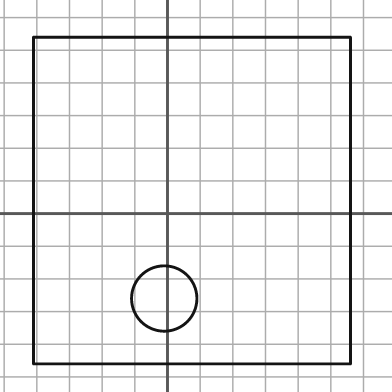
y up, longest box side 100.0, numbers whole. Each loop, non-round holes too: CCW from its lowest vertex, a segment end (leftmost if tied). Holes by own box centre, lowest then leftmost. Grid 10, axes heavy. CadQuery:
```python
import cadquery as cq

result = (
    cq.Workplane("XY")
    .moveTo(-41.0, -46.0)
    .lineTo(56.0, -46.0)
    .lineTo(56.0, 54.0)
    .lineTo(-41.0, 54.0)
    .close()
    .moveTo(-1.0, -26.0)
    .circle(10.0)
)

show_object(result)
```